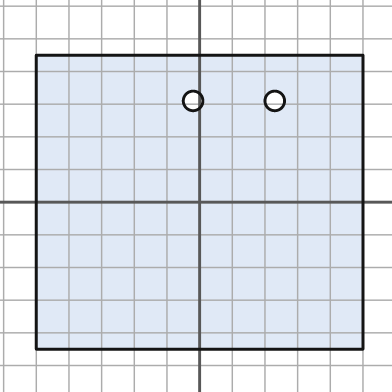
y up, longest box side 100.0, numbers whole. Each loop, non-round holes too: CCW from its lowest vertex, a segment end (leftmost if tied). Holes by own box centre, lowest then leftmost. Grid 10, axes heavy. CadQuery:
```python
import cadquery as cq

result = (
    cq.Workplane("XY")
    .moveTo(-50.0, -45.0)
    .lineTo(50.0, -45.0)
    .lineTo(50.0, 45.0)
    .lineTo(-50.0, 45.0)
    .close()
    .moveTo(-2.0, 31.0)
    .circle(3.0)
    .moveTo(23.0, 31.0)
    .circle(3.0)
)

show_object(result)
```